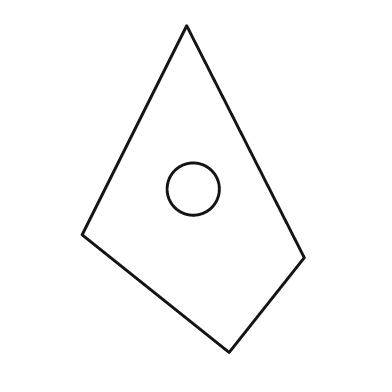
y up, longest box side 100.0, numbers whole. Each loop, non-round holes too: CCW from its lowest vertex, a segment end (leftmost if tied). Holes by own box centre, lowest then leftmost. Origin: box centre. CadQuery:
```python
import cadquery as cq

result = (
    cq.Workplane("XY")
    .moveTo(11.0, -50.0)
    .lineTo(34.0, -21.0)
    .lineTo(-2.0, 50.0)
    .lineTo(-34.0, -14.0)
    .close()
    .moveTo(0.0, 0.0)
    .circle(8.0)
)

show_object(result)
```